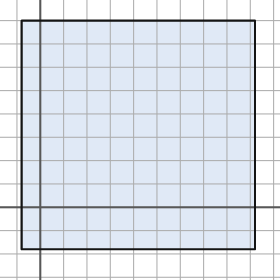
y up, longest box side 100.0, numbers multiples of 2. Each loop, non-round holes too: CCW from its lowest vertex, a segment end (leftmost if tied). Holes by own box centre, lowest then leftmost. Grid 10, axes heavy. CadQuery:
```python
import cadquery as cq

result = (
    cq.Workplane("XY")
    .moveTo(-8.0, -18.0)
    .lineTo(92.0, -18.0)
    .lineTo(92.0, 80.0)
    .lineTo(-8.0, 80.0)
    .close()
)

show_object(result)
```